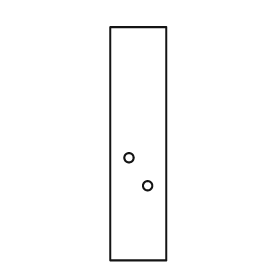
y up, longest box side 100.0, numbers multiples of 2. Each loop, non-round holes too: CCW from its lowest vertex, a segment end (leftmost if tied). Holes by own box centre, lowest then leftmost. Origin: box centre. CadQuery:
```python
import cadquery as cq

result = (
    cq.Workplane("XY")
    .moveTo(-12.0, -50.0)
    .lineTo(12.0, -50.0)
    .lineTo(12.0, 50.0)
    .lineTo(-12.0, 50.0)
    .close()
    .moveTo(4.0, -18.0)
    .circle(2.0)
    .moveTo(-4.0, -6.0)
    .circle(2.0)
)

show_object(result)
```